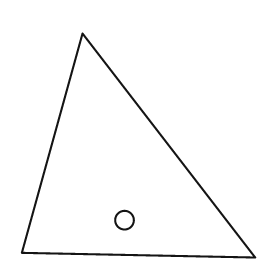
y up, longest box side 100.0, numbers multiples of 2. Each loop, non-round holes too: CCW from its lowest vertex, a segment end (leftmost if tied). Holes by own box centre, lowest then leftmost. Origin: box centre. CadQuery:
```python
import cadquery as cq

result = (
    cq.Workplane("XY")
    .moveTo(50.0, -48.0)
    .lineTo(-24.0, 48.0)
    .lineTo(-50.0, -46.0)
    .close()
    .moveTo(-6.0, -32.0)
    .circle(4.0)
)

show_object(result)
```